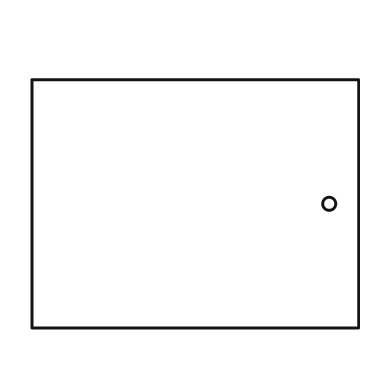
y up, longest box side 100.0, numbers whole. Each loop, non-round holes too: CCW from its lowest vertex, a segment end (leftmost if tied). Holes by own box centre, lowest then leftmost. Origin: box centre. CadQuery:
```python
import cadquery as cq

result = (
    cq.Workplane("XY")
    .moveTo(-50.0, -38.0)
    .lineTo(50.0, -38.0)
    .lineTo(50.0, 38.0)
    .lineTo(-50.0, 38.0)
    .close()
    .moveTo(41.0, 0.0)
    .circle(2.0)
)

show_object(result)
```